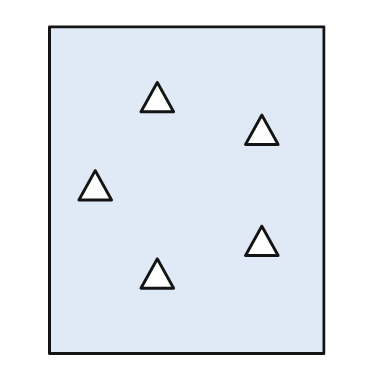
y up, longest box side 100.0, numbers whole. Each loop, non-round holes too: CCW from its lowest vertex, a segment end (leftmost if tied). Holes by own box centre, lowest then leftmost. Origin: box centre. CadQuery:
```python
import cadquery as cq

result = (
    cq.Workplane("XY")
    .moveTo(-42.0, -50.0)
    .lineTo(42.0, -50.0)
    .lineTo(42.0, 50.0)
    .lineTo(-42.0, 50.0)
    .close()
    .moveTo(-14.0, -30.0)
    .lineTo(-4.0, -30.0)
    .lineTo(-9.0, -21.0)
    .close()
    .moveTo(18.0, -20.0)
    .lineTo(28.0, -20.0)
    .lineTo(23.0, -11.0)
    .close()
    .moveTo(-33.0, -3.0)
    .lineTo(-23.0, -3.0)
    .lineTo(-28.0, 6.0)
    .close()
    .moveTo(18.0, 14.0)
    .lineTo(28.0, 14.0)
    .lineTo(23.0, 23.0)
    .close()
    .moveTo(-14.0, 24.0)
    .lineTo(-4.0, 24.0)
    .lineTo(-9.0, 33.0)
    .close()
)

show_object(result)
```